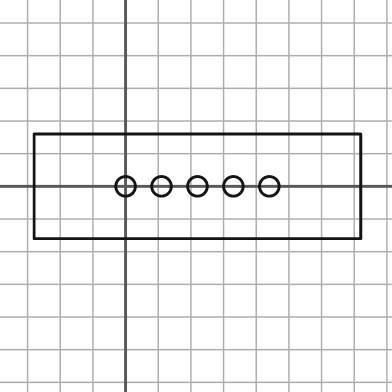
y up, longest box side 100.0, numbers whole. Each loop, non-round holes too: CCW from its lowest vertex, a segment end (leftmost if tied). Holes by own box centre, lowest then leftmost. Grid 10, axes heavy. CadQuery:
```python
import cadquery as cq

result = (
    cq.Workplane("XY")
    .moveTo(-28.0, -16.0)
    .lineTo(72.0, -16.0)
    .lineTo(72.0, 16.0)
    .lineTo(-28.0, 16.0)
    .close()
    .moveTo(0.0, 0.0)
    .circle(3.0)
    .moveTo(11.0, 0.0)
    .circle(3.0)
    .moveTo(22.0, 0.0)
    .circle(3.0)
    .moveTo(33.0, 0.0)
    .circle(3.0)
    .moveTo(44.0, 0.0)
    .circle(3.0)
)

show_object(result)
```